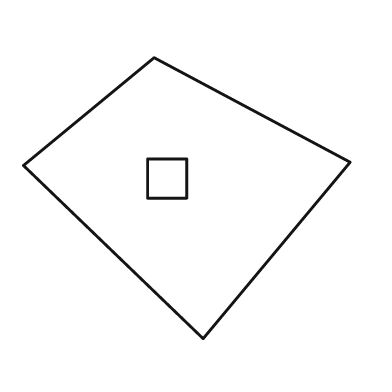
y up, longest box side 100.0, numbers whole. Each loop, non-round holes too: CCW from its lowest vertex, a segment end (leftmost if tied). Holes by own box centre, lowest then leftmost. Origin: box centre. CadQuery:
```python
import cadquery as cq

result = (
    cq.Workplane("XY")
    .moveTo(5.0, -43.0)
    .lineTo(50.0, 11.0)
    .lineTo(-10.0, 43.0)
    .lineTo(-50.0, 10.0)
    .close()
    .moveTo(-12.0, 0.0)
    .lineTo(0.0, 0.0)
    .lineTo(0.0, 12.0)
    .lineTo(-12.0, 12.0)
    .close()
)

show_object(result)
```